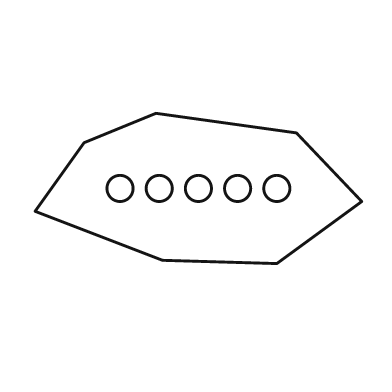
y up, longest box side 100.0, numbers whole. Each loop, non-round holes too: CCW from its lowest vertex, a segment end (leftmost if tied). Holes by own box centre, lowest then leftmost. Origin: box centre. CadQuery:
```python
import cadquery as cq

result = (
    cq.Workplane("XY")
    .moveTo(24.0, -23.0)
    .lineTo(50.0, -4.0)
    .lineTo(30.0, 17.0)
    .lineTo(-13.0, 23.0)
    .lineTo(-35.0, 14.0)
    .lineTo(-50.0, -7.0)
    .lineTo(-11.0, -22.0)
    .close()
    .moveTo(-24.0, 0.0)
    .circle(4.0)
    .moveTo(-12.0, 0.0)
    .circle(4.0)
    .moveTo(0.0, 0.0)
    .circle(4.0)
    .moveTo(12.0, 0.0)
    .circle(4.0)
    .moveTo(24.0, 0.0)
    .circle(4.0)
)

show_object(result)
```